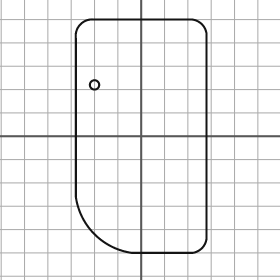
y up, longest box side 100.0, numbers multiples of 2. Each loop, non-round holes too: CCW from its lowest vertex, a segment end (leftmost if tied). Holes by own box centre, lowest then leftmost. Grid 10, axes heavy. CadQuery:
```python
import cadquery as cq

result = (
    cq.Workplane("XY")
    .moveTo(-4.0, -50.0)
    .lineTo(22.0, -50.0)
    .threePointArc((26.0, -48.0), (28.0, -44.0))
    .lineTo(28.0, 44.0)
    .threePointArc((26.0, 48.0), (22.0, 50.0))
    .lineTo(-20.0, 50.0)
    .threePointArc((-26.0, 48.0), (-28.0, 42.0))
    .lineTo(-28.0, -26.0)
    .threePointArc((-20.0, -42.0), (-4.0, -50.0))
    .close()
    .moveTo(-20.0, 22.0)
    .circle(2.0)
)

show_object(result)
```